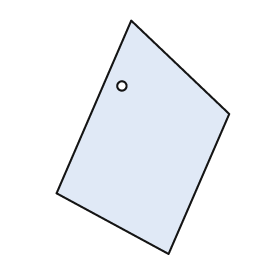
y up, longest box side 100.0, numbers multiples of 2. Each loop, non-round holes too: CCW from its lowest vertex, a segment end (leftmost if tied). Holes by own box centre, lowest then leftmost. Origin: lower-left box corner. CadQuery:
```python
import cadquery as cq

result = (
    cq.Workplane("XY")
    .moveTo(48.0, 0.0)
    .lineTo(74.0, 60.0)
    .lineTo(32.0, 100.0)
    .lineTo(0.0, 26.0)
    .close()
    .moveTo(28.0, 72.0)
    .circle(2.0)
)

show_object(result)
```